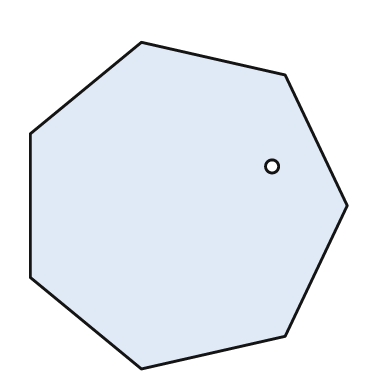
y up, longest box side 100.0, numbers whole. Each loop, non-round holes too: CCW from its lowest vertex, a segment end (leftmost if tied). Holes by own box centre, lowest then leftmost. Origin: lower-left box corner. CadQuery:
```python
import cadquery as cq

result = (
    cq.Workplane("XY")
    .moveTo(34.0, 0.0)
    .lineTo(78.0, 10.0)
    .lineTo(97.0, 50.0)
    .lineTo(78.0, 90.0)
    .lineTo(34.0, 100.0)
    .lineTo(0.0, 72.0)
    .lineTo(0.0, 28.0)
    .close()
    .moveTo(74.0, 62.0)
    .circle(2.0)
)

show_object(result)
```